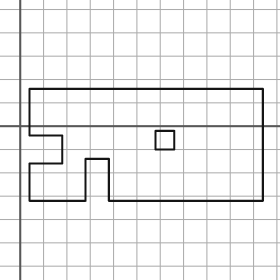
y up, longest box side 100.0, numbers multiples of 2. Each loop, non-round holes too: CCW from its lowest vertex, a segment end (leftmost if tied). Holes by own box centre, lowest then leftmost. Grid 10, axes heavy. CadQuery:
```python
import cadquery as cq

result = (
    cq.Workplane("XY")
    .moveTo(4.0, -32.0)
    .lineTo(28.0, -32.0)
    .lineTo(28.0, -14.0)
    .lineTo(38.0, -14.0)
    .lineTo(38.0, -32.0)
    .lineTo(104.0, -32.0)
    .lineTo(104.0, 16.0)
    .lineTo(4.0, 16.0)
    .lineTo(4.0, -4.0)
    .lineTo(18.0, -4.0)
    .lineTo(18.0, -16.0)
    .lineTo(4.0, -16.0)
    .close()
    .moveTo(58.0, -10.0)
    .lineTo(66.0, -10.0)
    .lineTo(66.0, -2.0)
    .lineTo(58.0, -2.0)
    .close()
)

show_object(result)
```